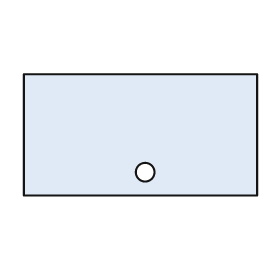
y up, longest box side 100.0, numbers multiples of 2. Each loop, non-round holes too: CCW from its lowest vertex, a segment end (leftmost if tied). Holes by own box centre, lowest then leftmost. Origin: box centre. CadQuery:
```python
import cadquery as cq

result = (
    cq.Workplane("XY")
    .moveTo(-50.0, -26.0)
    .lineTo(50.0, -26.0)
    .lineTo(50.0, 26.0)
    .lineTo(-50.0, 26.0)
    .close()
    .moveTo(2.0, -16.0)
    .circle(4.0)
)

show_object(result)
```